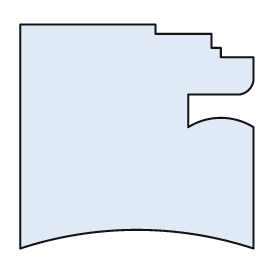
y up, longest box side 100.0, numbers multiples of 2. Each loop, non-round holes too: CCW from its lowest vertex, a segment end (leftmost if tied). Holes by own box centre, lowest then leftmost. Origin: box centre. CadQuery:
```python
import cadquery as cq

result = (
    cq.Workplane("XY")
    .moveTo(-50.0, -48.0)
    .threePointArc((0.0, -40.0), (50.0, -48.0))
    .lineTo(50.0, 4.0)
    .threePointArc((36.0, 8.0), (22.0, 4.0))
    .lineTo(22.0, 18.0)
    .lineTo(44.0, 18.0)
    .threePointArc((48.0, 20.0), (50.0, 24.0))
    .lineTo(50.0, 34.0)
    .lineTo(36.0, 34.0)
    .lineTo(36.0, 38.0)
    .lineTo(32.0, 38.0)
    .lineTo(32.0, 44.0)
    .lineTo(8.0, 44.0)
    .lineTo(8.0, 48.0)
    .lineTo(-50.0, 48.0)
    .close()
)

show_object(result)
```